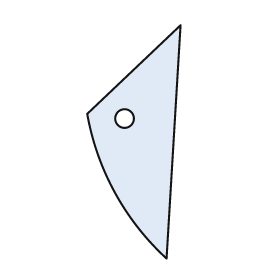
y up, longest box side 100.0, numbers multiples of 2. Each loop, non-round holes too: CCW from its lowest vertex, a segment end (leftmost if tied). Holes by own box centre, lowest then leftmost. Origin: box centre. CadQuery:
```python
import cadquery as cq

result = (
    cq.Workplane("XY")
    .moveTo(14.0, -50.0)
    .lineTo(20.0, 50.0)
    .lineTo(-20.0, 12.0)
    .threePointArc((-8.0, -22.0), (14.0, -50.0))
    .close()
    .moveTo(-4.0, 10.0)
    .circle(4.0)
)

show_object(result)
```